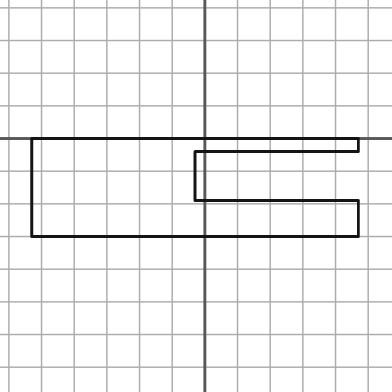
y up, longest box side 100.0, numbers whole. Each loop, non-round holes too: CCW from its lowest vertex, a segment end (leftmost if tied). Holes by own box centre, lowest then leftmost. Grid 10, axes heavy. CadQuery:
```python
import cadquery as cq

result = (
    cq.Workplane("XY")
    .moveTo(-53.0, -30.0)
    .lineTo(47.0, -30.0)
    .lineTo(47.0, -19.0)
    .lineTo(-3.0, -19.0)
    .lineTo(-3.0, -4.0)
    .lineTo(47.0, -4.0)
    .lineTo(47.0, 0.0)
    .lineTo(-53.0, 0.0)
    .close()
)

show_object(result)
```